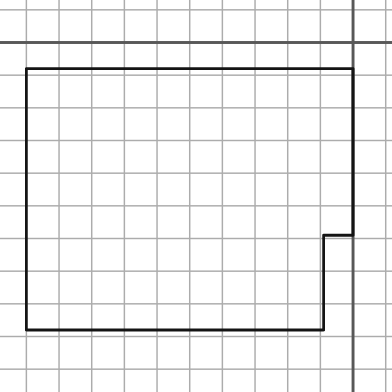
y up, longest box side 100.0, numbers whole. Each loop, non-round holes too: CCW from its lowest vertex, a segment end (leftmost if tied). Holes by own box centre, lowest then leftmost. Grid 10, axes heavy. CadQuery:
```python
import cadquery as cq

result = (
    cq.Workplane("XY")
    .moveTo(-100.0, -88.0)
    .lineTo(-9.0, -88.0)
    .lineTo(-9.0, -59.0)
    .lineTo(0.0, -59.0)
    .lineTo(0.0, -8.0)
    .lineTo(-100.0, -8.0)
    .close()
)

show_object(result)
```